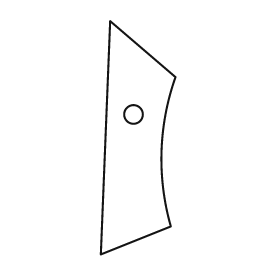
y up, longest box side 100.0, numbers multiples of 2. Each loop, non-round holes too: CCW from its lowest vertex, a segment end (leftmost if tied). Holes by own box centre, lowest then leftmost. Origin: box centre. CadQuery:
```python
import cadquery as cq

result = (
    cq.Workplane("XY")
    .moveTo(-16.0, -50.0)
    .lineTo(14.0, -38.0)
    .threePointArc((10.0, -6.0), (16.0, 26.0))
    .lineTo(-12.0, 50.0)
    .close()
    .moveTo(-2.0, 10.0)
    .circle(4.0)
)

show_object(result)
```